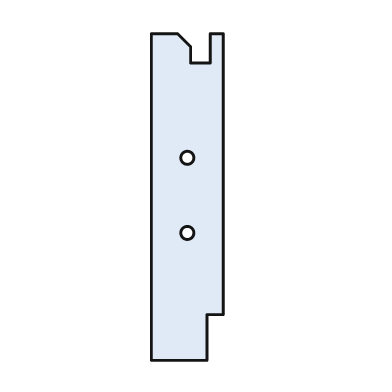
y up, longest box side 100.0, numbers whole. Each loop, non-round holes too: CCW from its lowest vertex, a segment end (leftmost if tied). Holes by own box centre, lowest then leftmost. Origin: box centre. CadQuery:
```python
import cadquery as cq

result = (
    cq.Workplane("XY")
    .moveTo(-11.0, -50.0)
    .lineTo(6.0, -50.0)
    .lineTo(6.0, -36.0)
    .lineTo(11.0, -36.0)
    .lineTo(11.0, 50.0)
    .lineTo(7.0, 50.0)
    .lineTo(7.0, 41.0)
    .lineTo(1.0, 41.0)
    .lineTo(1.0, 46.0)
    .lineTo(-3.0, 50.0)
    .lineTo(-11.0, 50.0)
    .close()
    .moveTo(0.0, -11.0)
    .circle(2.0)
    .moveTo(0.0, 12.0)
    .circle(2.0)
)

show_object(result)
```